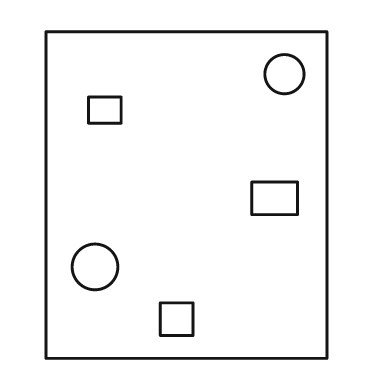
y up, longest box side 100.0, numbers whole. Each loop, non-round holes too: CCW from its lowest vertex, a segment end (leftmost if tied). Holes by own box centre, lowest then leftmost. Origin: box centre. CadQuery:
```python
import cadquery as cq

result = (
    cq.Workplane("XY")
    .moveTo(-43.0, -50.0)
    .lineTo(43.0, -50.0)
    .lineTo(43.0, 50.0)
    .lineTo(-43.0, 50.0)
    .close()
    .moveTo(-8.0, -43.0)
    .lineTo(2.0, -43.0)
    .lineTo(2.0, -33.0)
    .lineTo(-8.0, -33.0)
    .close()
    .moveTo(-28.0, -22.0)
    .circle(7.0)
    .moveTo(20.0, -6.0)
    .lineTo(34.0, -6.0)
    .lineTo(34.0, 4.0)
    .lineTo(20.0, 4.0)
    .close()
    .moveTo(-30.0, 22.0)
    .lineTo(-20.0, 22.0)
    .lineTo(-20.0, 30.0)
    .lineTo(-30.0, 30.0)
    .close()
    .moveTo(30.0, 37.0)
    .circle(6.0)
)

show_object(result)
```